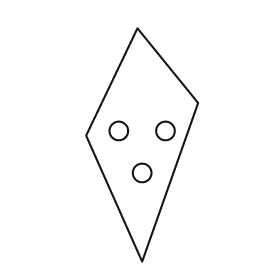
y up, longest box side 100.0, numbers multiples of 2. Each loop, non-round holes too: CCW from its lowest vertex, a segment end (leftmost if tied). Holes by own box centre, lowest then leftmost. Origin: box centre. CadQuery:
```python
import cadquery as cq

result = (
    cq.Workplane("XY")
    .moveTo(0.0, -50.0)
    .lineTo(24.0, 18.0)
    .lineTo(-2.0, 50.0)
    .lineTo(-24.0, 4.0)
    .close()
    .moveTo(0.0, -12.0)
    .circle(4.0)
    .moveTo(-10.0, 6.0)
    .circle(4.0)
    .moveTo(10.0, 6.0)
    .circle(4.0)
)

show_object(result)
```